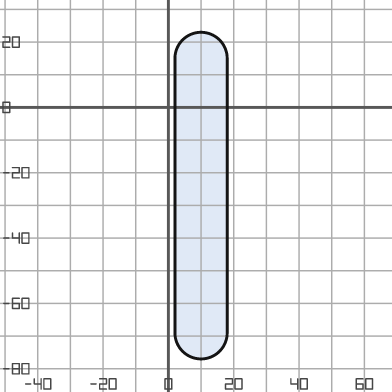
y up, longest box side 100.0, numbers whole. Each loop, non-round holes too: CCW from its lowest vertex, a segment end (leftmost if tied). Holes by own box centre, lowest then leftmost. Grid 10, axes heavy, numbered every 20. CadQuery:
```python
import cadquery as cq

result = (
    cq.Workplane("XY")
    .moveTo(2.0, -69.0)
    .threePointArc((10.0, -77.0), (18.0, -69.0))
    .lineTo(18.0, 15.0)
    .threePointArc((10.0, 23.0), (2.0, 15.0))
    .close()
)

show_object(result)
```